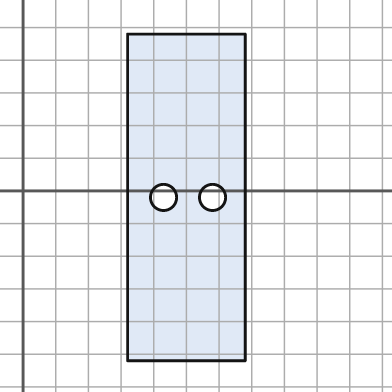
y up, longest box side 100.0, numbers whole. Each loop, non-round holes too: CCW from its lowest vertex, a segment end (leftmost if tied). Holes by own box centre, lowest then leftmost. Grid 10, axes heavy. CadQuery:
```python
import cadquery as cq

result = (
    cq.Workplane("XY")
    .moveTo(32.0, -52.0)
    .lineTo(68.0, -52.0)
    .lineTo(68.0, 48.0)
    .lineTo(32.0, 48.0)
    .close()
    .moveTo(43.0, -2.0)
    .circle(4.0)
    .moveTo(58.0, -2.0)
    .circle(4.0)
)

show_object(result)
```